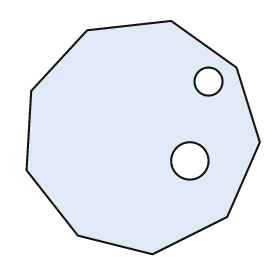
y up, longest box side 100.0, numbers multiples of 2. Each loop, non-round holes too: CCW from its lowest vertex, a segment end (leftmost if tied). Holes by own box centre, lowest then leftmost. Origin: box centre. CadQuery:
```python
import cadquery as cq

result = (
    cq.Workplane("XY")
    .moveTo(4.0, -50.0)
    .lineTo(36.0, -34.0)
    .lineTo(50.0, -2.0)
    .lineTo(40.0, 30.0)
    .lineTo(12.0, 50.0)
    .lineTo(-24.0, 46.0)
    .lineTo(-48.0, 20.0)
    .lineTo(-50.0, -14.0)
    .lineTo(-28.0, -42.0)
    .close()
    .moveTo(20.0, -10.0)
    .circle(8.0)
    .moveTo(28.0, 24.0)
    .circle(6.0)
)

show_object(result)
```